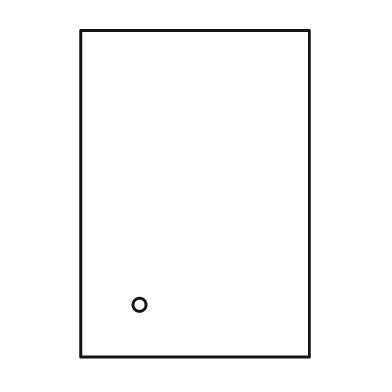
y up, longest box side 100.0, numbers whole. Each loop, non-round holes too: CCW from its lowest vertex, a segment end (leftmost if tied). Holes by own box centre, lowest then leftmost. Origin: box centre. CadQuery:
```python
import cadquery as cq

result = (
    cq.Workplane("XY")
    .moveTo(-35.0, -50.0)
    .lineTo(35.0, -50.0)
    .lineTo(35.0, 50.0)
    .lineTo(-35.0, 50.0)
    .close()
    .moveTo(-17.0, -34.0)
    .circle(2.0)
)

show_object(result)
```